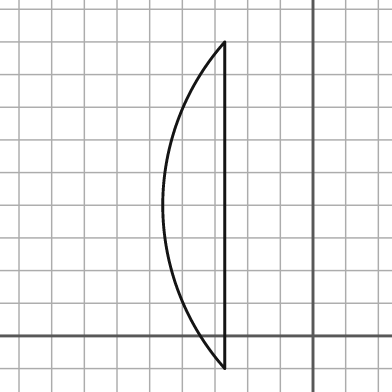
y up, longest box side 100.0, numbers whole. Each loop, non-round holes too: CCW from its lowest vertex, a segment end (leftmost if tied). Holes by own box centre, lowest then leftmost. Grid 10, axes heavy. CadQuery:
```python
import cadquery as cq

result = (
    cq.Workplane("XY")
    .moveTo(-27.0, -10.0)
    .lineTo(-27.0, 90.0)
    .threePointArc((-46.0, 40.0), (-27.0, -10.0))
    .close()
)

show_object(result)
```